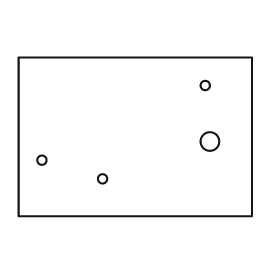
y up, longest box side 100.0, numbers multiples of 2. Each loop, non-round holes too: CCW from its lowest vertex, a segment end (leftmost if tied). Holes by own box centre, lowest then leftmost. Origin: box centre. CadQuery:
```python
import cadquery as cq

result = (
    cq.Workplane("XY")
    .moveTo(-50.0, -34.0)
    .lineTo(50.0, -34.0)
    .lineTo(50.0, 34.0)
    .lineTo(-50.0, 34.0)
    .close()
    .moveTo(-14.0, -18.0)
    .circle(2.0)
    .moveTo(-40.0, -10.0)
    .circle(2.0)
    .moveTo(32.0, -2.0)
    .circle(4.0)
    .moveTo(30.0, 22.0)
    .circle(2.0)
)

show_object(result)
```